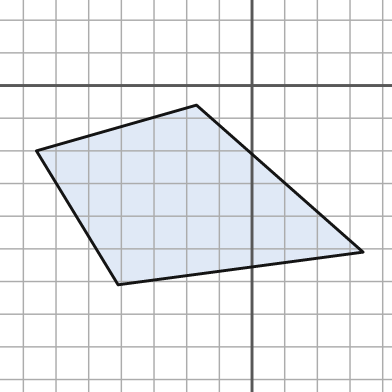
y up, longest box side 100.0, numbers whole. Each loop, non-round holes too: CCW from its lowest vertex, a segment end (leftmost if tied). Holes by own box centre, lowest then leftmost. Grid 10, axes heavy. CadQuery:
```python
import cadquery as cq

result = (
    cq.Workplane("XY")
    .moveTo(-41.0, -61.0)
    .lineTo(34.0, -51.0)
    .lineTo(-17.0, -6.0)
    .lineTo(-66.0, -20.0)
    .close()
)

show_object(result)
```